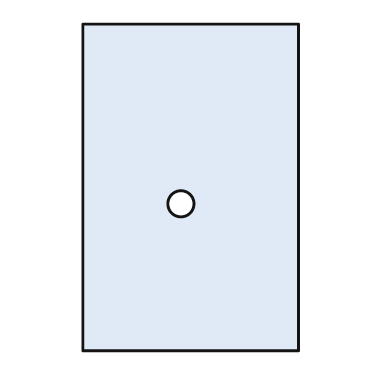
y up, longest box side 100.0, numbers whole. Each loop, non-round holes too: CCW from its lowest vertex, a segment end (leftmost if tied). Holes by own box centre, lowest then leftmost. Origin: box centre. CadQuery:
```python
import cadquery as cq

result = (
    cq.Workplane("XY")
    .moveTo(-33.0, -50.0)
    .lineTo(33.0, -50.0)
    .lineTo(33.0, 50.0)
    .lineTo(-33.0, 50.0)
    .close()
    .moveTo(-3.0, -5.0)
    .circle(4.0)
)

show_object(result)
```